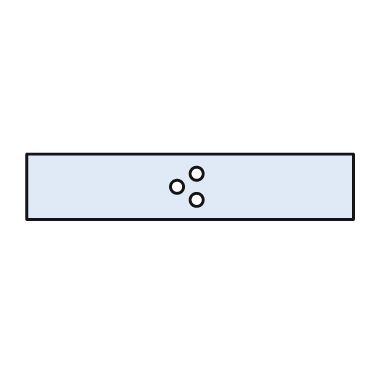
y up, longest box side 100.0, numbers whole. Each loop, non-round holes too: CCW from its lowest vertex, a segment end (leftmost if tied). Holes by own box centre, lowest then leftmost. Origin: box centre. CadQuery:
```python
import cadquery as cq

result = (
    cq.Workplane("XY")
    .moveTo(-50.0, -10.0)
    .lineTo(50.0, -10.0)
    .lineTo(50.0, 10.0)
    .lineTo(-50.0, 10.0)
    .close()
    .moveTo(2.0, -4.0)
    .circle(2.0)
    .moveTo(-4.0, 0.0)
    .circle(2.0)
    .moveTo(2.0, 4.0)
    .circle(2.0)
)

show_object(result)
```